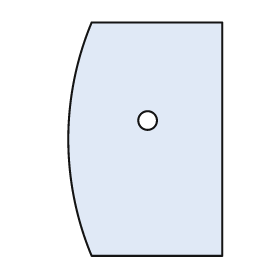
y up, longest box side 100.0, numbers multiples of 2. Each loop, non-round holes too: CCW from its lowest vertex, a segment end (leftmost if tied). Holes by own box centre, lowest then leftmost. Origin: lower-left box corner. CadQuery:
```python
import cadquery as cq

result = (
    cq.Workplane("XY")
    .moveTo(10.0, 0.0)
    .lineTo(66.0, 0.0)
    .lineTo(66.0, 100.0)
    .lineTo(10.0, 100.0)
    .threePointArc((0.0, 50.0), (10.0, 0.0))
    .close()
    .moveTo(34.0, 58.0)
    .circle(4.0)
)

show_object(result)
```